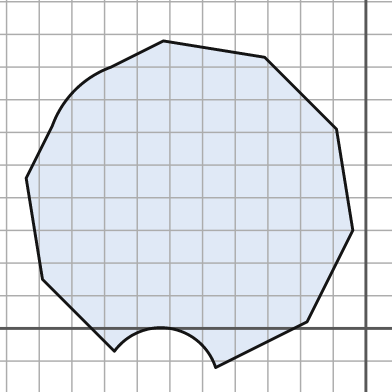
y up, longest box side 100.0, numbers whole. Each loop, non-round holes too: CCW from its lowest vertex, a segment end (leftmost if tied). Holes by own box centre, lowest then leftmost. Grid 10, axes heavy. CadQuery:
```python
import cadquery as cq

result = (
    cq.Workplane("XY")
    .moveTo(-46.0, -12.0)
    .lineTo(-18.0, 2.0)
    .lineTo(-4.0, 30.0)
    .lineTo(-9.0, 61.0)
    .lineTo(-31.0, 83.0)
    .lineTo(-62.0, 88.0)
    .lineTo(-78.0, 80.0)
    .threePointArc((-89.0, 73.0), (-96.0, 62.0))
    .lineTo(-104.0, 46.0)
    .lineTo(-99.0, 15.0)
    .lineTo(-77.0, -7.0)
    .threePointArc((-60.0, 0.0), (-46.0, -12.0))
    .close()
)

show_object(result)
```